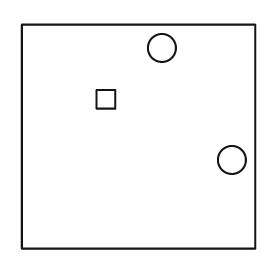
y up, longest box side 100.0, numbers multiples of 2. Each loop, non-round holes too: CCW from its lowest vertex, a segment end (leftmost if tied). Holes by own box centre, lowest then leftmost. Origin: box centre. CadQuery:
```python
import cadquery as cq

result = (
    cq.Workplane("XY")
    .moveTo(-50.0, -48.0)
    .lineTo(50.0, -48.0)
    .lineTo(50.0, 48.0)
    .lineTo(-50.0, 48.0)
    .close()
    .moveTo(40.0, -10.0)
    .circle(6.0)
    .moveTo(-18.0, 12.0)
    .lineTo(-10.0, 12.0)
    .lineTo(-10.0, 20.0)
    .lineTo(-18.0, 20.0)
    .close()
    .moveTo(10.0, 38.0)
    .circle(6.0)
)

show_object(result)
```